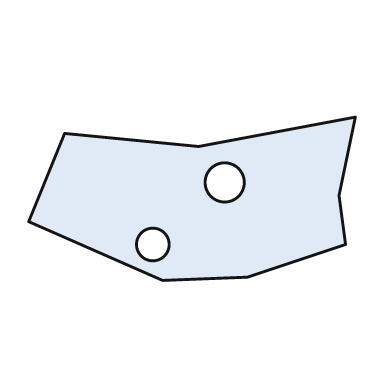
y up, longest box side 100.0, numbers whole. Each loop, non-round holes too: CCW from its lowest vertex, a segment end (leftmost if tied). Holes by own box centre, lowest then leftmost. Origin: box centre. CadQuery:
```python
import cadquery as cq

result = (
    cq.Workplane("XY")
    .moveTo(-9.0, -25.0)
    .lineTo(17.0, -24.0)
    .lineTo(47.0, -14.0)
    .lineTo(45.0, 1.0)
    .lineTo(50.0, 25.0)
    .lineTo(2.0, 16.0)
    .lineTo(-39.0, 20.0)
    .lineTo(-50.0, -7.0)
    .close()
    .moveTo(-12.0, -14.0)
    .circle(5.0)
    .moveTo(10.0, 5.0)
    .circle(6.0)
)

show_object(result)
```